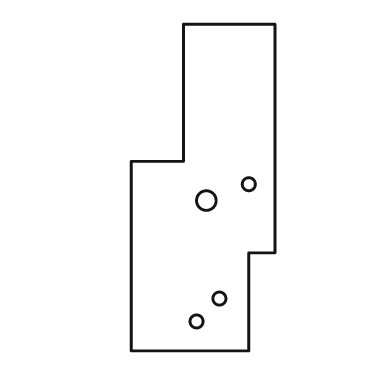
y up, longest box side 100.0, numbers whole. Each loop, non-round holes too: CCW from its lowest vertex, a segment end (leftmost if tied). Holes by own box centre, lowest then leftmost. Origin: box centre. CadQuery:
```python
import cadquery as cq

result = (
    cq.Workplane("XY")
    .moveTo(-22.0, -50.0)
    .lineTo(14.0, -50.0)
    .lineTo(14.0, -20.0)
    .lineTo(22.0, -20.0)
    .lineTo(22.0, 50.0)
    .lineTo(-6.0, 50.0)
    .lineTo(-6.0, 8.0)
    .lineTo(-22.0, 8.0)
    .close()
    .moveTo(-2.0, -41.0)
    .circle(2.0)
    .moveTo(5.0, -34.0)
    .circle(2.0)
    .moveTo(1.0, -4.0)
    .circle(3.0)
    .moveTo(14.0, 1.0)
    .circle(2.0)
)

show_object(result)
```